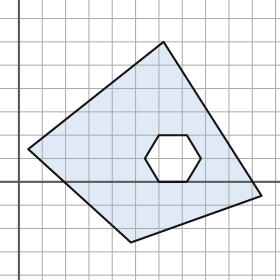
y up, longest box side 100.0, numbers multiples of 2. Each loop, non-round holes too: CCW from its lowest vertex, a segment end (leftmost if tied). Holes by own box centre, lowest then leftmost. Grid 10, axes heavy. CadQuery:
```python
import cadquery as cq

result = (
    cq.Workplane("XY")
    .moveTo(48.0, -26.0)
    .lineTo(104.0, -6.0)
    .lineTo(62.0, 60.0)
    .lineTo(4.0, 14.0)
    .close()
    .moveTo(60.0, 0.0)
    .lineTo(72.0, 0.0)
    .lineTo(78.0, 10.0)
    .lineTo(72.0, 20.0)
    .lineTo(60.0, 20.0)
    .lineTo(54.0, 10.0)
    .close()
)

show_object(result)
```